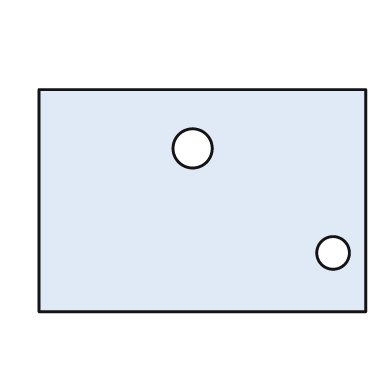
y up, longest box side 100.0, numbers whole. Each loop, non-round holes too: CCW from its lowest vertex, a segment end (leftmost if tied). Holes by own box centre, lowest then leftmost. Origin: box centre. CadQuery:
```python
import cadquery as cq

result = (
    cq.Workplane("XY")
    .moveTo(-50.0, -34.0)
    .lineTo(50.0, -34.0)
    .lineTo(50.0, 34.0)
    .lineTo(-50.0, 34.0)
    .close()
    .moveTo(40.0, -16.0)
    .circle(5.0)
    .moveTo(-3.0, 16.0)
    .circle(6.0)
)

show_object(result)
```